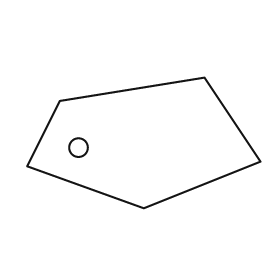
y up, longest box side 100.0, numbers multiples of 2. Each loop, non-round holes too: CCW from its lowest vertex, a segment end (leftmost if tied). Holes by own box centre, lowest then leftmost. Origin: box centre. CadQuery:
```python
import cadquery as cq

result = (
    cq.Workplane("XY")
    .moveTo(0.0, -28.0)
    .lineTo(50.0, -8.0)
    .lineTo(26.0, 28.0)
    .lineTo(-36.0, 18.0)
    .lineTo(-50.0, -10.0)
    .close()
    .moveTo(-28.0, -2.0)
    .circle(4.0)
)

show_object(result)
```